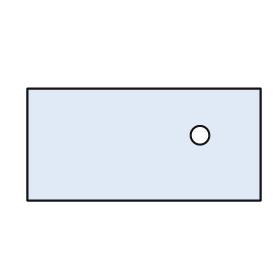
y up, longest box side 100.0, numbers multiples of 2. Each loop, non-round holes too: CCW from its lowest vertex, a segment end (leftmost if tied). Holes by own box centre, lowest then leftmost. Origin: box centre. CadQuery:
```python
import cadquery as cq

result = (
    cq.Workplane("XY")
    .moveTo(-50.0, -24.0)
    .lineTo(50.0, -24.0)
    .lineTo(50.0, 24.0)
    .lineTo(-50.0, 24.0)
    .close()
    .moveTo(24.0, 4.0)
    .circle(4.0)
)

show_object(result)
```